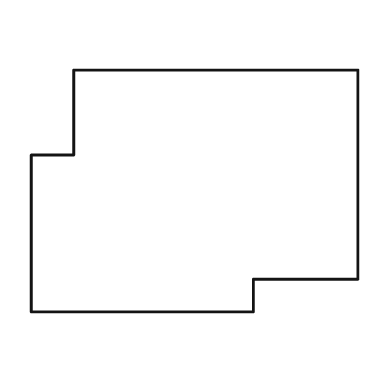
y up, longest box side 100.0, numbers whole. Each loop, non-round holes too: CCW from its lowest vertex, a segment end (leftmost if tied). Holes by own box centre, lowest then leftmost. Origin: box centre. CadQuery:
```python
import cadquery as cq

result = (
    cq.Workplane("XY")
    .moveTo(-50.0, -37.0)
    .lineTo(18.0, -37.0)
    .lineTo(18.0, -27.0)
    .lineTo(50.0, -27.0)
    .lineTo(50.0, 37.0)
    .lineTo(-37.0, 37.0)
    .lineTo(-37.0, 11.0)
    .lineTo(-50.0, 11.0)
    .close()
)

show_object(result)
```